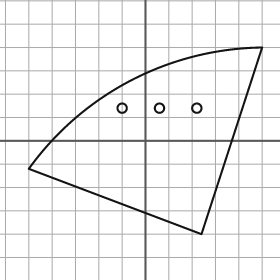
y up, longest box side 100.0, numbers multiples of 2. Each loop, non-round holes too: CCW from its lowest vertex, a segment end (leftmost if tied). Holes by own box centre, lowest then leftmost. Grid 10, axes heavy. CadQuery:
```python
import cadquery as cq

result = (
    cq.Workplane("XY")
    .moveTo(24.0, -40.0)
    .lineTo(50.0, 40.0)
    .threePointArc((-6.0, 26.0), (-50.0, -12.0))
    .close()
    .moveTo(-10.0, 14.0)
    .circle(2.0)
    .moveTo(6.0, 14.0)
    .circle(2.0)
    .moveTo(22.0, 14.0)
    .circle(2.0)
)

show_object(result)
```